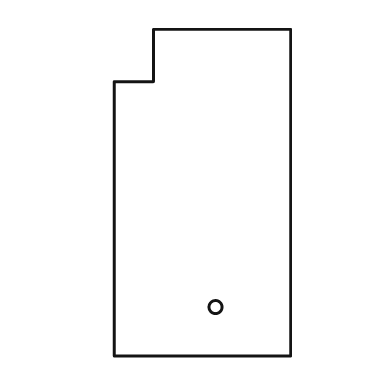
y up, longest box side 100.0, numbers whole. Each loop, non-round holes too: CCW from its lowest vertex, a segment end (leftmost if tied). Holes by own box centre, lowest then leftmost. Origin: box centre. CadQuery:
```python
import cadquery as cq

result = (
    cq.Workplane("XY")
    .moveTo(-27.0, -50.0)
    .lineTo(27.0, -50.0)
    .lineTo(27.0, 50.0)
    .lineTo(-15.0, 50.0)
    .lineTo(-15.0, 34.0)
    .lineTo(-27.0, 34.0)
    .close()
    .moveTo(4.0, -35.0)
    .circle(2.0)
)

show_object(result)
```